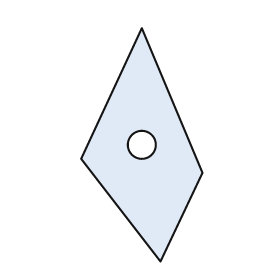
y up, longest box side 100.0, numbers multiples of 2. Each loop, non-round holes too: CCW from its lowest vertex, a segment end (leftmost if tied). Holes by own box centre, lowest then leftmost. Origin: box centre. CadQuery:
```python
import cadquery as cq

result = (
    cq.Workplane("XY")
    .moveTo(8.0, -50.0)
    .lineTo(26.0, -12.0)
    .lineTo(0.0, 50.0)
    .lineTo(-26.0, -6.0)
    .close()
    .moveTo(0.0, 0.0)
    .circle(6.0)
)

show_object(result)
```